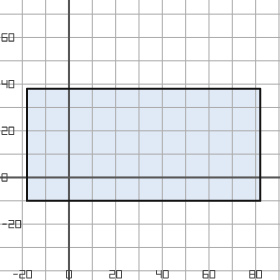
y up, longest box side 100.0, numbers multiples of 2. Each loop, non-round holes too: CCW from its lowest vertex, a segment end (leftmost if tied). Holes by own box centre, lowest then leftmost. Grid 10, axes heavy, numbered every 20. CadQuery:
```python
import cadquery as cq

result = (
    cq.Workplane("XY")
    .moveTo(-18.0, -10.0)
    .lineTo(82.0, -10.0)
    .lineTo(82.0, 38.0)
    .lineTo(-18.0, 38.0)
    .close()
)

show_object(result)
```